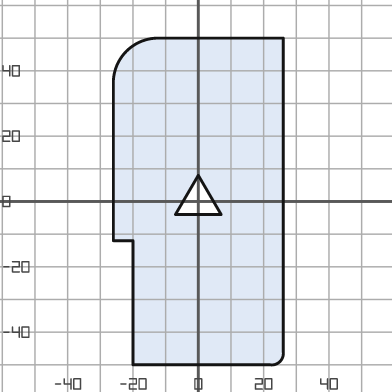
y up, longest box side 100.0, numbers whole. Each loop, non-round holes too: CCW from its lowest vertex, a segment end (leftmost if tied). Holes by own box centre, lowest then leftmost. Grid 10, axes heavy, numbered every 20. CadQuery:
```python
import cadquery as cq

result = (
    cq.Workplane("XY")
    .moveTo(-20.0, -50.0)
    .lineTo(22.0, -50.0)
    .threePointArc((25.0, -49.0), (26.0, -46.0))
    .lineTo(26.0, 50.0)
    .lineTo(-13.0, 50.0)
    .threePointArc((-22.0, 46.0), (-26.0, 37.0))
    .lineTo(-26.0, -12.0)
    .lineTo(-20.0, -12.0)
    .close()
    .moveTo(-7.0, -4.0)
    .lineTo(7.0, -4.0)
    .lineTo(0.0, 8.0)
    .close()
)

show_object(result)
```